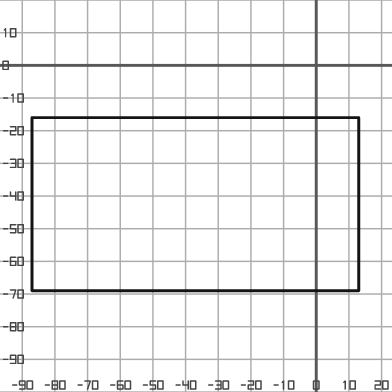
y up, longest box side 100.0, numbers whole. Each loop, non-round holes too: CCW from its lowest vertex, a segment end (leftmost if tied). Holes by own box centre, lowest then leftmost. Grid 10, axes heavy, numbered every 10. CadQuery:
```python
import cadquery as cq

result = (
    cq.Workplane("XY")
    .moveTo(-87.0, -69.0)
    .lineTo(13.0, -69.0)
    .lineTo(13.0, -16.0)
    .lineTo(-87.0, -16.0)
    .close()
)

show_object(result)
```